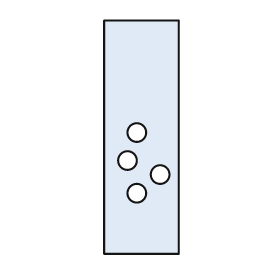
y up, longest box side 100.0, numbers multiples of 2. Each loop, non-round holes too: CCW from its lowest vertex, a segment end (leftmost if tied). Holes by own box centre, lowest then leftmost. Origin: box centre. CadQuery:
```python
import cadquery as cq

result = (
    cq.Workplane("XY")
    .moveTo(-16.0, -50.0)
    .lineTo(16.0, -50.0)
    .lineTo(16.0, 50.0)
    .lineTo(-16.0, 50.0)
    .close()
    .moveTo(-2.0, -24.0)
    .circle(4.0)
    .moveTo(8.0, -16.0)
    .circle(4.0)
    .moveTo(-6.0, -10.0)
    .circle(4.0)
    .moveTo(-2.0, 2.0)
    .circle(4.0)
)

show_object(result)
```